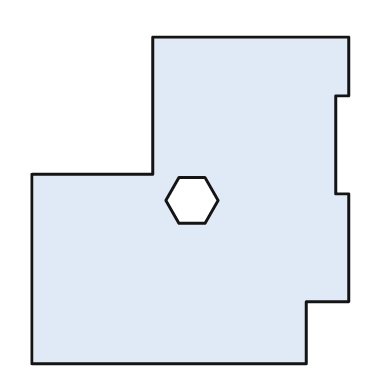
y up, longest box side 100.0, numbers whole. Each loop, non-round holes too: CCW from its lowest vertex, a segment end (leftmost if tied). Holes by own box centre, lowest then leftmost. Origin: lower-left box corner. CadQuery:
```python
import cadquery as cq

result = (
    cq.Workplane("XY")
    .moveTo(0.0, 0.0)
    .lineTo(84.0, 0.0)
    .lineTo(84.0, 19.0)
    .lineTo(97.0, 19.0)
    .lineTo(97.0, 52.0)
    .lineTo(93.0, 52.0)
    .lineTo(93.0, 82.0)
    .lineTo(97.0, 82.0)
    .lineTo(97.0, 100.0)
    .lineTo(37.0, 100.0)
    .lineTo(37.0, 58.0)
    .lineTo(0.0, 58.0)
    .close()
    .moveTo(45.0, 43.0)
    .lineTo(53.0, 43.0)
    .lineTo(57.0, 50.0)
    .lineTo(53.0, 57.0)
    .lineTo(45.0, 57.0)
    .lineTo(41.0, 50.0)
    .close()
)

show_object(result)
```